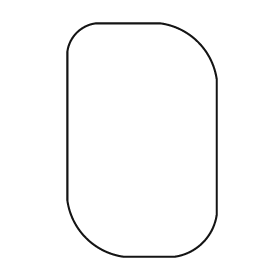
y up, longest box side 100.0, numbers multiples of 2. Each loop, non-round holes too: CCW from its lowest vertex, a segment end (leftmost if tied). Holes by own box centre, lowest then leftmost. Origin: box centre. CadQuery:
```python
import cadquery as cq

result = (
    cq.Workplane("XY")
    .moveTo(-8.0, -50.0)
    .lineTo(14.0, -50.0)
    .threePointArc((26.0, -44.0), (32.0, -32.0))
    .lineTo(32.0, 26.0)
    .threePointArc((24.0, 42.0), (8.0, 50.0))
    .lineTo(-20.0, 50.0)
    .threePointArc((-28.0, 46.0), (-32.0, 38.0))
    .lineTo(-32.0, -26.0)
    .threePointArc((-24.0, -42.0), (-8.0, -50.0))
    .close()
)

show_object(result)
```